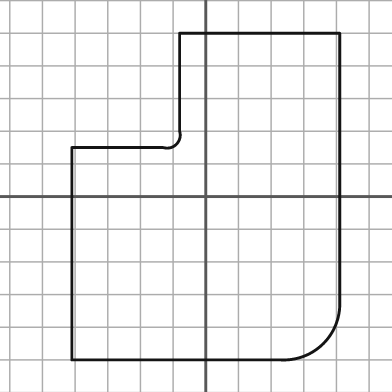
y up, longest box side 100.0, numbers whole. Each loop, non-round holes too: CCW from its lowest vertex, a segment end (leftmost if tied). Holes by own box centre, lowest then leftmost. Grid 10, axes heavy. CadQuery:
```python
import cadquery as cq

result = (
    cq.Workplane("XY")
    .moveTo(-41.0, -50.0)
    .lineTo(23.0, -50.0)
    .threePointArc((36.0, -45.0), (41.0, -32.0))
    .lineTo(41.0, 50.0)
    .lineTo(-8.0, 50.0)
    .lineTo(-8.0, 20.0)
    .threePointArc((-9.0, 16.0), (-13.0, 15.0))
    .lineTo(-41.0, 15.0)
    .close()
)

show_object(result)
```